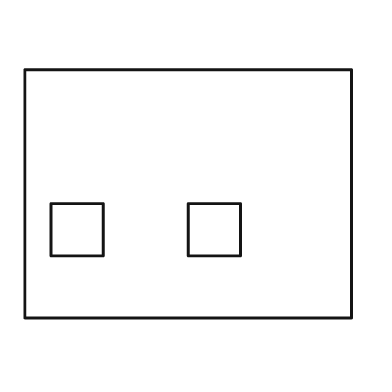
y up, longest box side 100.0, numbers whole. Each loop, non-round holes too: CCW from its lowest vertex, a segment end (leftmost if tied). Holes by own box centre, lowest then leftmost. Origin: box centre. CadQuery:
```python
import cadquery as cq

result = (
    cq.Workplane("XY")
    .moveTo(-50.0, -38.0)
    .lineTo(50.0, -38.0)
    .lineTo(50.0, 38.0)
    .lineTo(-50.0, 38.0)
    .close()
    .moveTo(-42.0, -19.0)
    .lineTo(-26.0, -19.0)
    .lineTo(-26.0, -3.0)
    .lineTo(-42.0, -3.0)
    .close()
    .moveTo(0.0, -19.0)
    .lineTo(16.0, -19.0)
    .lineTo(16.0, -3.0)
    .lineTo(0.0, -3.0)
    .close()
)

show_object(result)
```